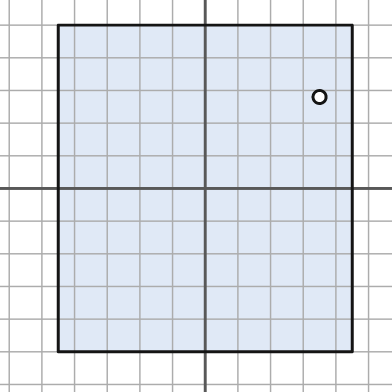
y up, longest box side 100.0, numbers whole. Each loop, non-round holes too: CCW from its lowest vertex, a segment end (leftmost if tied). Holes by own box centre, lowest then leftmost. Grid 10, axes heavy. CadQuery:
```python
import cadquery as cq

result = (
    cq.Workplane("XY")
    .moveTo(-45.0, -50.0)
    .lineTo(45.0, -50.0)
    .lineTo(45.0, 50.0)
    .lineTo(-45.0, 50.0)
    .close()
    .moveTo(35.0, 28.0)
    .circle(2.0)
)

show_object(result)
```